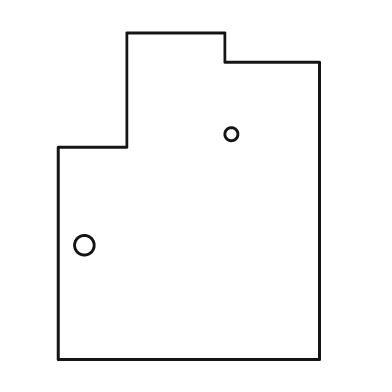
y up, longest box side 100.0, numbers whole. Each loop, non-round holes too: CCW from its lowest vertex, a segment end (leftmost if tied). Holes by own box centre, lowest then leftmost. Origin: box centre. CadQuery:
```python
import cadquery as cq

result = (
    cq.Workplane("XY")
    .moveTo(-40.0, -50.0)
    .lineTo(40.0, -50.0)
    .lineTo(40.0, 41.0)
    .lineTo(11.0, 41.0)
    .lineTo(11.0, 50.0)
    .lineTo(-19.0, 50.0)
    .lineTo(-19.0, 15.0)
    .lineTo(-40.0, 15.0)
    .close()
    .moveTo(-32.0, -15.0)
    .circle(3.0)
    .moveTo(13.0, 19.0)
    .circle(2.0)
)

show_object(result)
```